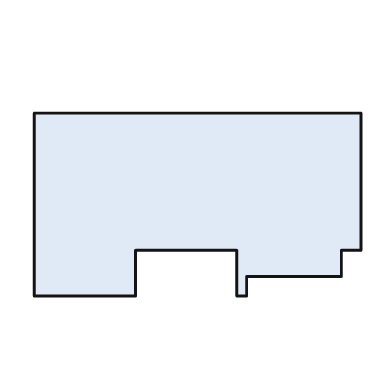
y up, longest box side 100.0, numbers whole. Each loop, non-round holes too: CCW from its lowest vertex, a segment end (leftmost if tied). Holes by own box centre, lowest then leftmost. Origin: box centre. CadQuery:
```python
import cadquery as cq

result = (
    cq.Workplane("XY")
    .moveTo(-50.0, -28.0)
    .lineTo(-19.0, -28.0)
    .lineTo(-19.0, -14.0)
    .lineTo(12.0, -14.0)
    .lineTo(12.0, -28.0)
    .lineTo(15.0, -28.0)
    .lineTo(15.0, -22.0)
    .lineTo(44.0, -22.0)
    .lineTo(44.0, -14.0)
    .lineTo(50.0, -14.0)
    .lineTo(50.0, 28.0)
    .lineTo(-50.0, 28.0)
    .close()
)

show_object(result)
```